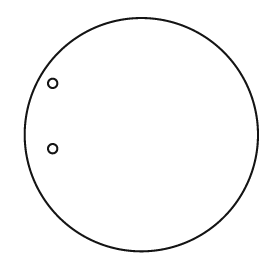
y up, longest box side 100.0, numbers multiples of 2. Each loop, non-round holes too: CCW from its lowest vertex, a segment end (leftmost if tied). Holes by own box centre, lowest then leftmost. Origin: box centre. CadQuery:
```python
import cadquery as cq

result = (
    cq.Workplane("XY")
    .moveTo(0.0, 0.0)
    .circle(50.0)
    .moveTo(-38.0, -6.0)
    .circle(2.0)
    .moveTo(-38.0, 22.0)
    .circle(2.0)
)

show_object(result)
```